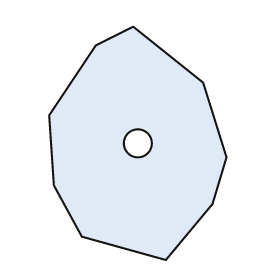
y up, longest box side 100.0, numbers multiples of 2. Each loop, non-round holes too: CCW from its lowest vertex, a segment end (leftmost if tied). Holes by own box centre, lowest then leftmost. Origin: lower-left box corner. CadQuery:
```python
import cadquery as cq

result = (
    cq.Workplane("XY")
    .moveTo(50.0, 0.0)
    .lineTo(70.0, 24.0)
    .lineTo(76.0, 44.0)
    .lineTo(66.0, 76.0)
    .lineTo(36.0, 100.0)
    .lineTo(20.0, 92.0)
    .lineTo(0.0, 62.0)
    .lineTo(2.0, 32.0)
    .lineTo(14.0, 10.0)
    .close()
    .moveTo(38.0, 50.0)
    .circle(6.0)
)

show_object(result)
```